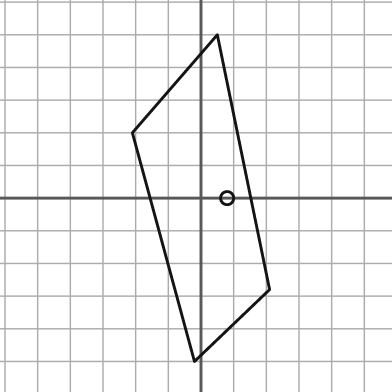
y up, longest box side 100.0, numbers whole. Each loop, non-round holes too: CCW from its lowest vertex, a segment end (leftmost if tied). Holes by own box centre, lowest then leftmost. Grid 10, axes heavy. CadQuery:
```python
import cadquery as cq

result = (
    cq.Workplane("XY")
    .moveTo(-2.0, -50.0)
    .lineTo(21.0, -28.0)
    .lineTo(5.0, 50.0)
    .lineTo(-21.0, 20.0)
    .close()
    .moveTo(8.0, 0.0)
    .circle(2.0)
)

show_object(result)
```